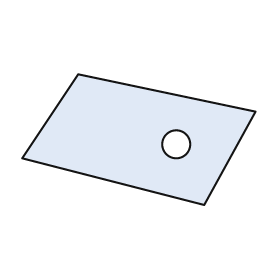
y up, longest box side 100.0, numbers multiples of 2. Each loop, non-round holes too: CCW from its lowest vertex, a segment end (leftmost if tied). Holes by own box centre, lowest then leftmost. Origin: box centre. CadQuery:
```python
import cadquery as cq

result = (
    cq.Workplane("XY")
    .moveTo(28.0, -28.0)
    .lineTo(50.0, 12.0)
    .lineTo(-26.0, 28.0)
    .lineTo(-50.0, -8.0)
    .close()
    .moveTo(16.0, -2.0)
    .circle(6.0)
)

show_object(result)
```